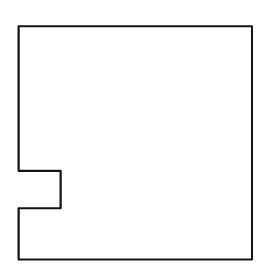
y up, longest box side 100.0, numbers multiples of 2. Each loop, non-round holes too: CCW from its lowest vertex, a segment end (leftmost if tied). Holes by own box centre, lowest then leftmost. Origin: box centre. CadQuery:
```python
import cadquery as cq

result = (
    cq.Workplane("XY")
    .moveTo(-50.0, -50.0)
    .lineTo(50.0, -50.0)
    .lineTo(50.0, 50.0)
    .lineTo(-50.0, 50.0)
    .lineTo(-50.0, -12.0)
    .lineTo(-32.0, -12.0)
    .lineTo(-32.0, -28.0)
    .lineTo(-50.0, -28.0)
    .close()
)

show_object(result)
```